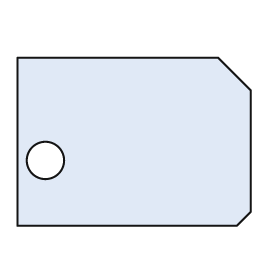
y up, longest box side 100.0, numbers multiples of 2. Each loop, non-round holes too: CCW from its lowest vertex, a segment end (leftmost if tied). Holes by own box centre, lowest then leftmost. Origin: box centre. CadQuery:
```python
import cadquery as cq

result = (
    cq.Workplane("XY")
    .moveTo(-50.0, -36.0)
    .lineTo(44.0, -36.0)
    .lineTo(50.0, -30.0)
    .lineTo(50.0, 22.0)
    .lineTo(36.0, 36.0)
    .lineTo(-50.0, 36.0)
    .close()
    .moveTo(-38.0, -8.0)
    .circle(8.0)
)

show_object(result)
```